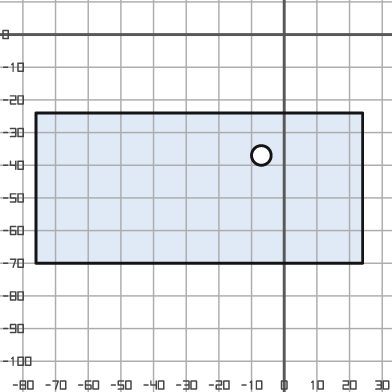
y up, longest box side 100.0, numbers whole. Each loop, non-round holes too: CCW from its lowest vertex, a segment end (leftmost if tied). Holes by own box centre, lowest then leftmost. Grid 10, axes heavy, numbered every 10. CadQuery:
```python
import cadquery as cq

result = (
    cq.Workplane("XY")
    .moveTo(-76.0, -70.0)
    .lineTo(24.0, -70.0)
    .lineTo(24.0, -24.0)
    .lineTo(-76.0, -24.0)
    .close()
    .moveTo(-7.0, -37.0)
    .circle(3.0)
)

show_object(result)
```